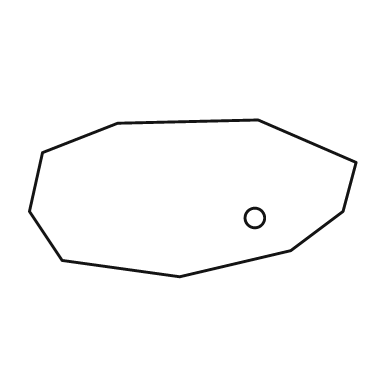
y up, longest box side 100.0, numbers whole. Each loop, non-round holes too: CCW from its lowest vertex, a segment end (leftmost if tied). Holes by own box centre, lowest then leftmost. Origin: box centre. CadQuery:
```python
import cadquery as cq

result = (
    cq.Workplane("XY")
    .moveTo(-4.0, -24.0)
    .lineTo(30.0, -16.0)
    .lineTo(46.0, -4.0)
    .lineTo(50.0, 11.0)
    .lineTo(20.0, 24.0)
    .lineTo(-23.0, 23.0)
    .lineTo(-46.0, 14.0)
    .lineTo(-50.0, -4.0)
    .lineTo(-40.0, -19.0)
    .close()
    .moveTo(19.0, -6.0)
    .circle(3.0)
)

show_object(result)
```